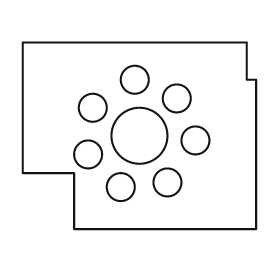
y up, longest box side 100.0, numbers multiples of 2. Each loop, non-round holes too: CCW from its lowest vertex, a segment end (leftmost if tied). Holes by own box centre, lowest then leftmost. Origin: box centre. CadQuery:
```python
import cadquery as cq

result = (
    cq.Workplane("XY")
    .moveTo(-28.0, -40.0)
    .lineTo(50.0, -40.0)
    .lineTo(50.0, 24.0)
    .lineTo(46.0, 24.0)
    .lineTo(46.0, 40.0)
    .lineTo(-50.0, 40.0)
    .lineTo(-50.0, -16.0)
    .lineTo(-28.0, -16.0)
    .close()
    .moveTo(-8.0, -22.0)
    .circle(6.0)
    .moveTo(12.0, -20.0)
    .circle(6.0)
    .moveTo(-22.0, -8.0)
    .circle(6.0)
    .moveTo(24.0, -2.0)
    .circle(6.0)
    .moveTo(0.0, 0.0)
    .circle(12.0)
    .moveTo(-20.0, 12.0)
    .circle(6.0)
    .moveTo(16.0, 16.0)
    .circle(6.0)
    .moveTo(-2.0, 24.0)
    .circle(6.0)
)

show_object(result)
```